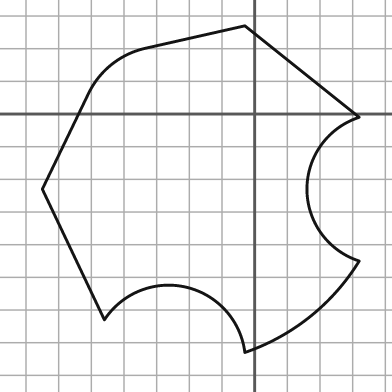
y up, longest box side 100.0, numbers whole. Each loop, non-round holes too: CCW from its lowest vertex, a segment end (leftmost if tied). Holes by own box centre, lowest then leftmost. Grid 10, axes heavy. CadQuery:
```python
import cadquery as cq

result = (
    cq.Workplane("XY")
    .moveTo(-3.0, -73.0)
    .threePointArc((17.0, -62.0), (32.0, -45.0))
    .threePointArc((16.0, -23.0), (32.0, -1.0))
    .lineTo(-3.0, 27.0)
    .lineTo(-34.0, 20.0)
    .threePointArc((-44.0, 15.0), (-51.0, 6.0))
    .lineTo(-65.0, -23.0)
    .lineTo(-46.0, -63.0)
    .threePointArc((-21.0, -53.0), (-3.0, -73.0))
    .close()
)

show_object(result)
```